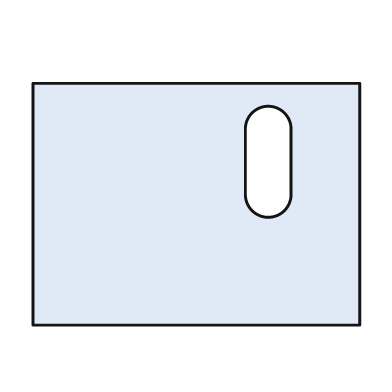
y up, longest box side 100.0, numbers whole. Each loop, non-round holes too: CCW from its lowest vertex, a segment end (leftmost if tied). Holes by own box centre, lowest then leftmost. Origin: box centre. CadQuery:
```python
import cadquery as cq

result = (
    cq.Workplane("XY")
    .moveTo(-50.0, -37.0)
    .lineTo(50.0, -37.0)
    .lineTo(50.0, 37.0)
    .lineTo(-50.0, 37.0)
    .close()
    .moveTo(15.0, 3.0)
    .threePointArc((22.0, -4.0), (29.0, 3.0))
    .lineTo(29.0, 23.0)
    .threePointArc((22.0, 30.0), (15.0, 23.0))
    .close()
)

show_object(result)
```